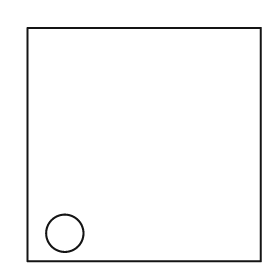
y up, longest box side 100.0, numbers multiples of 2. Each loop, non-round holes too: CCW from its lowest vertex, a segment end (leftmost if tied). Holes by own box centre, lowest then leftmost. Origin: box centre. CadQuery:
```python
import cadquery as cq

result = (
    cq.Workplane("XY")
    .moveTo(-50.0, -50.0)
    .lineTo(50.0, -50.0)
    .lineTo(50.0, 50.0)
    .lineTo(-50.0, 50.0)
    .close()
    .moveTo(-34.0, -38.0)
    .circle(8.0)
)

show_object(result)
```